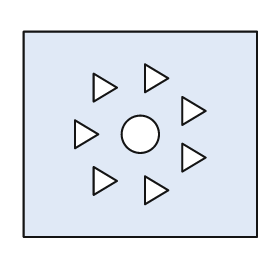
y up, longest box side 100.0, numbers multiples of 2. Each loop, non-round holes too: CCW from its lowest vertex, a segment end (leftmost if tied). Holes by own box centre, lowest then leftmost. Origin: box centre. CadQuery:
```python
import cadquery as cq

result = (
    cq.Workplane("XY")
    .moveTo(-50.0, -44.0)
    .lineTo(50.0, -44.0)
    .lineTo(50.0, 44.0)
    .lineTo(-50.0, 44.0)
    .close()
    .moveTo(2.0, -30.0)
    .lineTo(12.0, -24.0)
    .lineTo(2.0, -18.0)
    .close()
    .moveTo(-20.0, -26.0)
    .lineTo(-10.0, -20.0)
    .lineTo(-20.0, -14.0)
    .close()
    .moveTo(18.0, -16.0)
    .lineTo(28.0, -10.0)
    .lineTo(18.0, -4.0)
    .close()
    .moveTo(-28.0, -6.0)
    .lineTo(-18.0, 0.0)
    .lineTo(-28.0, 6.0)
    .close()
    .moveTo(0.0, 0.0)
    .circle(8.0)
    .moveTo(18.0, 4.0)
    .lineTo(28.0, 10.0)
    .lineTo(18.0, 16.0)
    .close()
    .moveTo(-20.0, 14.0)
    .lineTo(-10.0, 20.0)
    .lineTo(-20.0, 26.0)
    .close()
    .moveTo(2.0, 18.0)
    .lineTo(12.0, 24.0)
    .lineTo(2.0, 30.0)
    .close()
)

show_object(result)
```